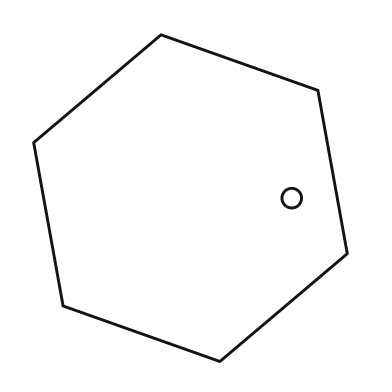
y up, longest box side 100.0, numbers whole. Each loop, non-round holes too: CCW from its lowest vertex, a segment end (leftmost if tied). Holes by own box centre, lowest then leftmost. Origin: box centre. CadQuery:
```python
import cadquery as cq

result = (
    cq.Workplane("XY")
    .moveTo(9.0, -50.0)
    .lineTo(48.0, -17.0)
    .lineTo(39.0, 33.0)
    .lineTo(-9.0, 50.0)
    .lineTo(-48.0, 17.0)
    .lineTo(-39.0, -33.0)
    .close()
    .moveTo(31.0, 0.0)
    .circle(3.0)
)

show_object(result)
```